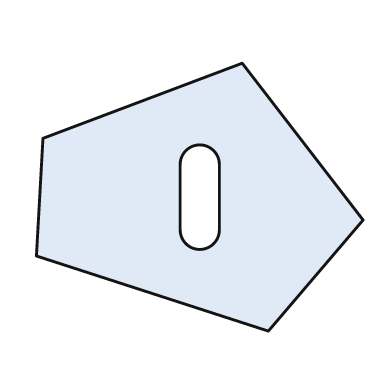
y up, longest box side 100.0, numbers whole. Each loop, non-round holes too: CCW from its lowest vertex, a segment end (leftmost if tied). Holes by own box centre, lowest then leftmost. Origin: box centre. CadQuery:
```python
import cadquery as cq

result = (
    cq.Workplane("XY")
    .moveTo(21.0, -41.0)
    .lineTo(50.0, -7.0)
    .lineTo(13.0, 41.0)
    .lineTo(-48.0, 18.0)
    .lineTo(-50.0, -18.0)
    .close()
    .moveTo(-6.0, -10.0)
    .threePointArc((0.0, -16.0), (6.0, -10.0))
    .lineTo(6.0, 10.0)
    .threePointArc((0.0, 16.0), (-6.0, 10.0))
    .close()
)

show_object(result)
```